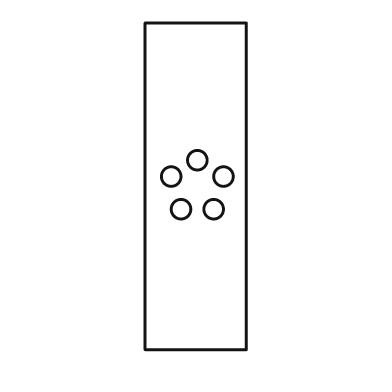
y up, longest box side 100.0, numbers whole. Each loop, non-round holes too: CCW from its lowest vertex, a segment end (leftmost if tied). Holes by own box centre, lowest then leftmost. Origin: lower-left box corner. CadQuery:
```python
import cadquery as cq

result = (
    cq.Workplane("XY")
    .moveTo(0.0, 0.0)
    .lineTo(31.0, 0.0)
    .lineTo(31.0, 100.0)
    .lineTo(0.0, 100.0)
    .close()
    .moveTo(11.0, 43.0)
    .circle(3.0)
    .moveTo(21.0, 43.0)
    .circle(3.0)
    .moveTo(8.0, 53.0)
    .circle(3.0)
    .moveTo(24.0, 53.0)
    .circle(3.0)
    .moveTo(16.0, 58.0)
    .circle(3.0)
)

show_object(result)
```